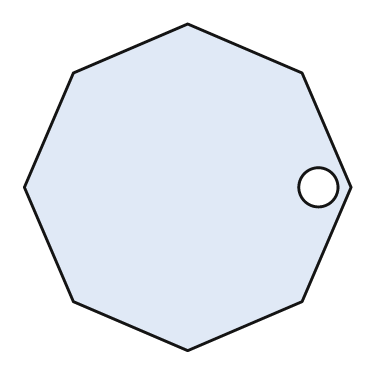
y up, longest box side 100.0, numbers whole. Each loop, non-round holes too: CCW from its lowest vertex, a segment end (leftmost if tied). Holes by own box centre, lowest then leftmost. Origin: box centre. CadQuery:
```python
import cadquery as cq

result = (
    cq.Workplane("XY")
    .moveTo(0.0, -50.0)
    .lineTo(35.0, -35.0)
    .lineTo(50.0, 0.0)
    .lineTo(35.0, 35.0)
    .lineTo(0.0, 50.0)
    .lineTo(-35.0, 35.0)
    .lineTo(-50.0, 0.0)
    .lineTo(-35.0, -35.0)
    .close()
    .moveTo(40.0, 0.0)
    .circle(6.0)
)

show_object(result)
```